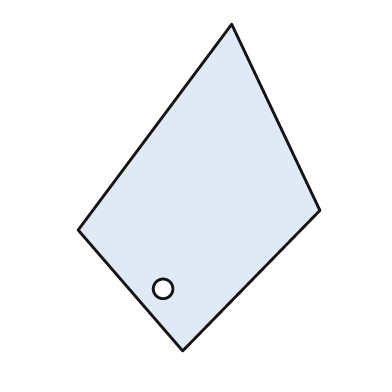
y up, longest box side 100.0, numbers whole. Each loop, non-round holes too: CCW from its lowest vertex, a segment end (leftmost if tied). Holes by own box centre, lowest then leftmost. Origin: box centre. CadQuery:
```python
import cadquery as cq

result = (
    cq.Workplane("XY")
    .moveTo(-5.0, -50.0)
    .lineTo(37.0, -7.0)
    .lineTo(10.0, 50.0)
    .lineTo(-37.0, -13.0)
    .close()
    .moveTo(-11.0, -31.0)
    .circle(3.0)
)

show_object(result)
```